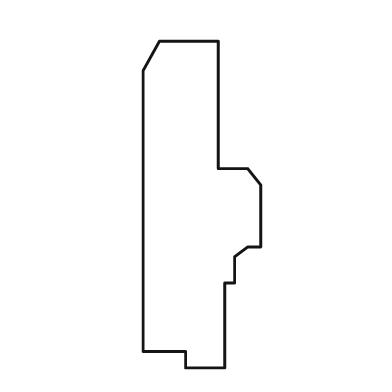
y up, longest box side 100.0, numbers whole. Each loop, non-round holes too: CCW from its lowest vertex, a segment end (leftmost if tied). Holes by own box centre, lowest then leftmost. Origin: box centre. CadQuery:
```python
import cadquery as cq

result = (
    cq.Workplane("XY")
    .moveTo(-5.0, -50.0)
    .lineTo(7.0, -50.0)
    .lineTo(7.0, -24.0)
    .lineTo(10.0, -24.0)
    .lineTo(10.0, -16.0)
    .lineTo(14.0, -13.0)
    .lineTo(18.0, -13.0)
    .lineTo(18.0, 6.0)
    .lineTo(14.0, 11.0)
    .lineTo(5.0, 11.0)
    .lineTo(5.0, 50.0)
    .lineTo(-13.0, 50.0)
    .lineTo(-18.0, 41.0)
    .lineTo(-18.0, -45.0)
    .lineTo(-5.0, -45.0)
    .close()
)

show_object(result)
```